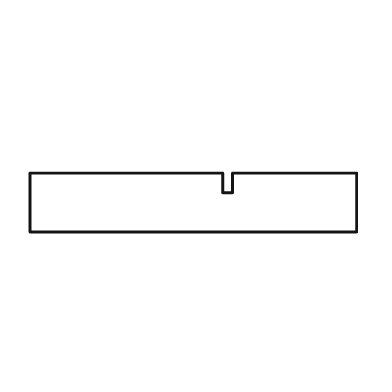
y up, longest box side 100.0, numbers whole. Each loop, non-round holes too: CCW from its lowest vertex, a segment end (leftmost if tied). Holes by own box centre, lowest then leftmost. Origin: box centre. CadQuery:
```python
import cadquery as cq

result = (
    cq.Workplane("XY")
    .moveTo(-50.0, -9.0)
    .lineTo(50.0, -9.0)
    .lineTo(50.0, 9.0)
    .lineTo(12.0, 9.0)
    .lineTo(12.0, 3.0)
    .lineTo(9.0, 3.0)
    .lineTo(9.0, 9.0)
    .lineTo(-50.0, 9.0)
    .close()
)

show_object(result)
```